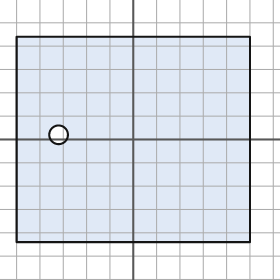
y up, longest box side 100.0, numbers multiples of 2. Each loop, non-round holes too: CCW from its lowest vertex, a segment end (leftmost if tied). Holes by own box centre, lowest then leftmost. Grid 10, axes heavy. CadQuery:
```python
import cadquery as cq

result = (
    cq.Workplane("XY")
    .moveTo(-50.0, -44.0)
    .lineTo(50.0, -44.0)
    .lineTo(50.0, 44.0)
    .lineTo(-50.0, 44.0)
    .close()
    .moveTo(-32.0, 2.0)
    .circle(4.0)
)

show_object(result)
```